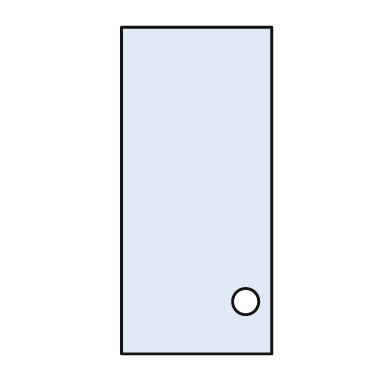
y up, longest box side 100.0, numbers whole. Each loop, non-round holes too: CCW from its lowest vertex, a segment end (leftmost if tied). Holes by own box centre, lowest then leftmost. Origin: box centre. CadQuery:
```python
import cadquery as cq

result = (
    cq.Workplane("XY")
    .moveTo(-23.0, -50.0)
    .lineTo(23.0, -50.0)
    .lineTo(23.0, 50.0)
    .lineTo(-23.0, 50.0)
    .close()
    .moveTo(15.0, -34.0)
    .circle(4.0)
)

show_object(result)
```